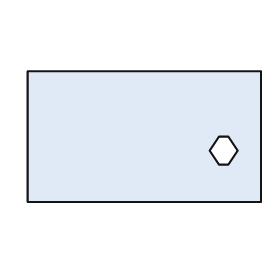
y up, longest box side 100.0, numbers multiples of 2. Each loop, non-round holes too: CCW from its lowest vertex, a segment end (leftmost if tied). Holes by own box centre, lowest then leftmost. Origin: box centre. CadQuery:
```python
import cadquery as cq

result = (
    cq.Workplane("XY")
    .moveTo(-50.0, -28.0)
    .lineTo(50.0, -28.0)
    .lineTo(50.0, 28.0)
    .lineTo(-50.0, 28.0)
    .close()
    .moveTo(32.0, -12.0)
    .lineTo(36.0, -12.0)
    .lineTo(40.0, -6.0)
    .lineTo(36.0, 0.0)
    .lineTo(32.0, 0.0)
    .lineTo(28.0, -6.0)
    .close()
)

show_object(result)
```